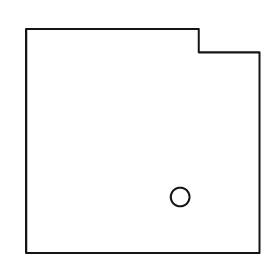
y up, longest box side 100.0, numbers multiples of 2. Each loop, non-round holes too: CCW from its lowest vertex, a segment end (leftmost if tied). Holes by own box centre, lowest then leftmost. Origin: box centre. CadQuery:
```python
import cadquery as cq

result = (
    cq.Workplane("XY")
    .moveTo(-50.0, -48.0)
    .lineTo(50.0, -48.0)
    .lineTo(50.0, 38.0)
    .lineTo(24.0, 38.0)
    .lineTo(24.0, 48.0)
    .lineTo(-50.0, 48.0)
    .close()
    .moveTo(16.0, -24.0)
    .circle(4.0)
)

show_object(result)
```